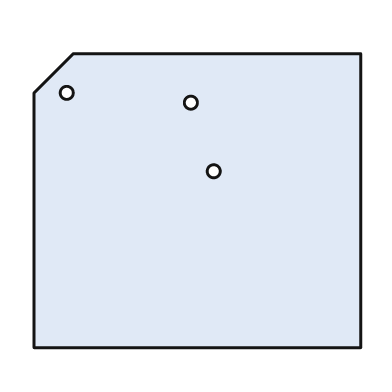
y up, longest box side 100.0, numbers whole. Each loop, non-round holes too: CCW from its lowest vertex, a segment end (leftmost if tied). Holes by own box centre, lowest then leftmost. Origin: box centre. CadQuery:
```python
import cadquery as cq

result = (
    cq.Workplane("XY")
    .moveTo(-50.0, -45.0)
    .lineTo(50.0, -45.0)
    .lineTo(50.0, 45.0)
    .lineTo(-38.0, 45.0)
    .lineTo(-50.0, 33.0)
    .close()
    .moveTo(5.0, 9.0)
    .circle(2.0)
    .moveTo(-2.0, 30.0)
    .circle(2.0)
    .moveTo(-40.0, 33.0)
    .circle(2.0)
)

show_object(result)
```